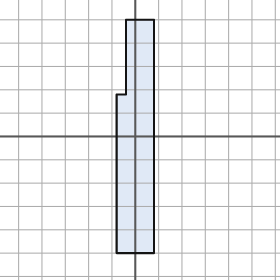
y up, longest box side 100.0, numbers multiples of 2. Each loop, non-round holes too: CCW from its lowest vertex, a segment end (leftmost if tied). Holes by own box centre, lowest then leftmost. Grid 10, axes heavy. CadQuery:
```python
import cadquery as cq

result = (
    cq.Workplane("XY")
    .moveTo(-8.0, -50.0)
    .lineTo(8.0, -50.0)
    .lineTo(8.0, 50.0)
    .lineTo(-4.0, 50.0)
    .lineTo(-4.0, 18.0)
    .lineTo(-8.0, 18.0)
    .close()
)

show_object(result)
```